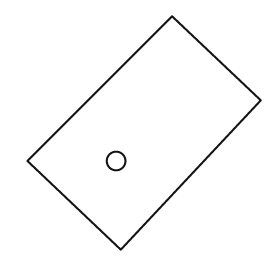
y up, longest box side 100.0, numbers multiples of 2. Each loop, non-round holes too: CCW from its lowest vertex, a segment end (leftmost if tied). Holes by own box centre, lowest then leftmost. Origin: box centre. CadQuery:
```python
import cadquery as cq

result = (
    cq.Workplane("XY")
    .moveTo(-10.0, -50.0)
    .lineTo(50.0, 14.0)
    .lineTo(12.0, 50.0)
    .lineTo(-50.0, -12.0)
    .close()
    .moveTo(-12.0, -12.0)
    .circle(4.0)
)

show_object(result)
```